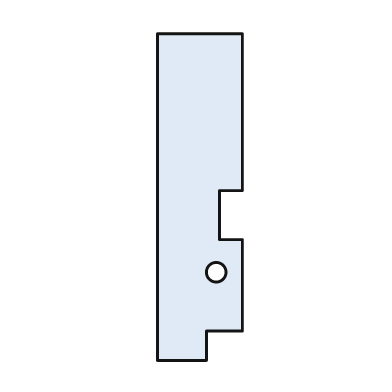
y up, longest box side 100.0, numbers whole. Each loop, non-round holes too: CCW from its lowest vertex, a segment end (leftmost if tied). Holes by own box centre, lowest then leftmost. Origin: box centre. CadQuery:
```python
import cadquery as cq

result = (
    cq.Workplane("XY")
    .moveTo(-13.0, -50.0)
    .lineTo(2.0, -50.0)
    .lineTo(2.0, -41.0)
    .lineTo(13.0, -41.0)
    .lineTo(13.0, -13.0)
    .lineTo(6.0, -13.0)
    .lineTo(6.0, 2.0)
    .lineTo(13.0, 2.0)
    .lineTo(13.0, 50.0)
    .lineTo(-13.0, 50.0)
    .close()
    .moveTo(5.0, -23.0)
    .circle(3.0)
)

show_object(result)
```